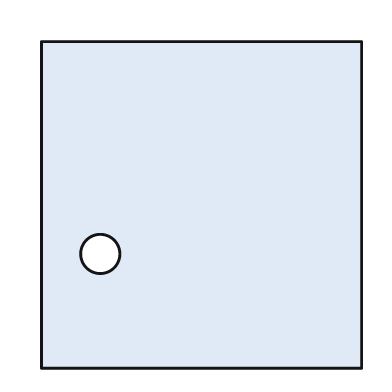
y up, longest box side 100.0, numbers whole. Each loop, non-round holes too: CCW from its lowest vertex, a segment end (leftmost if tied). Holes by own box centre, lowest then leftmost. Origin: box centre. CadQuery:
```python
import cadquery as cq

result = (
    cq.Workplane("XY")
    .moveTo(-49.0, -50.0)
    .lineTo(49.0, -50.0)
    .lineTo(49.0, 50.0)
    .lineTo(-49.0, 50.0)
    .close()
    .moveTo(-31.0, -15.0)
    .circle(6.0)
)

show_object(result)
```